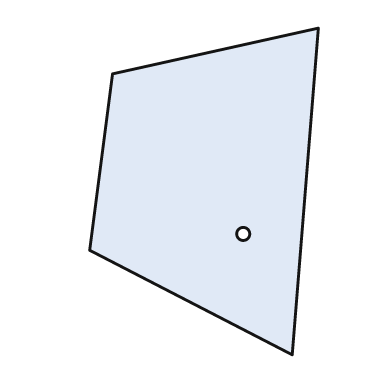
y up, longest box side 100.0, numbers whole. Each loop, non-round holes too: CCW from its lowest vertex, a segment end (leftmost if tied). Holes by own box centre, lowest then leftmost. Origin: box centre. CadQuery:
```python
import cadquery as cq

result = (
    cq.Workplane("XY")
    .moveTo(27.0, -50.0)
    .lineTo(35.0, 50.0)
    .lineTo(-28.0, 36.0)
    .lineTo(-35.0, -18.0)
    .close()
    .moveTo(12.0, -13.0)
    .circle(2.0)
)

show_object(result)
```